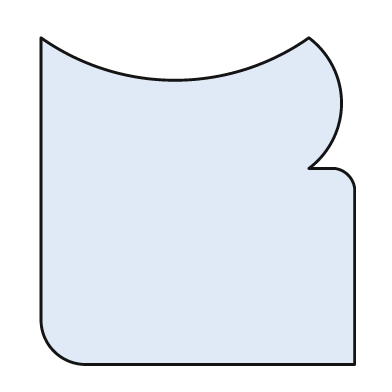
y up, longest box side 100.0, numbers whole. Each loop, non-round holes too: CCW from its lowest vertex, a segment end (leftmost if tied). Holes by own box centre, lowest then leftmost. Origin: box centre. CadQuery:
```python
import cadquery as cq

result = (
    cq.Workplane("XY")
    .moveTo(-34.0, -50.0)
    .lineTo(48.0, -50.0)
    .lineTo(48.0, 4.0)
    .threePointArc((46.0, 8.0), (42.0, 10.0))
    .lineTo(34.0, 10.0)
    .threePointArc((44.0, 30.0), (34.0, 50.0))
    .threePointArc((-7.0, 37.0), (-48.0, 50.0))
    .lineTo(-48.0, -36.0)
    .threePointArc((-44.0, -46.0), (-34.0, -50.0))
    .close()
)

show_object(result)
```